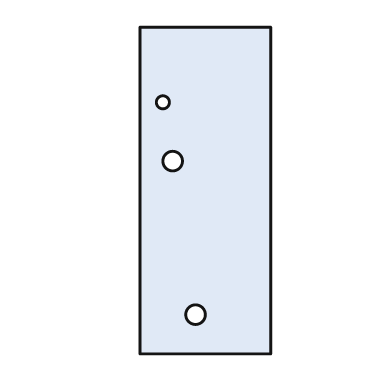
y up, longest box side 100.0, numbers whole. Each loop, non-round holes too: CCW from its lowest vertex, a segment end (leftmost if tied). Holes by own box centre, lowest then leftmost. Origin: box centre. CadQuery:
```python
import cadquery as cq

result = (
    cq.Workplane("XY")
    .moveTo(-20.0, -50.0)
    .lineTo(20.0, -50.0)
    .lineTo(20.0, 50.0)
    .lineTo(-20.0, 50.0)
    .close()
    .moveTo(-3.0, -38.0)
    .circle(3.0)
    .moveTo(-10.0, 9.0)
    .circle(3.0)
    .moveTo(-13.0, 27.0)
    .circle(2.0)
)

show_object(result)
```